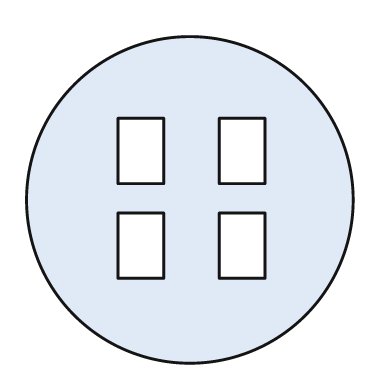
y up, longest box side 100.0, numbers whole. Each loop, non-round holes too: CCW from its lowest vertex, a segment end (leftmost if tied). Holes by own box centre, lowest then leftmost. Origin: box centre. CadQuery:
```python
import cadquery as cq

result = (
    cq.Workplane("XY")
    .moveTo(0.0, 0.0)
    .circle(50.0)
    .moveTo(-22.0, -24.0)
    .lineTo(-8.0, -24.0)
    .lineTo(-8.0, -4.0)
    .lineTo(-22.0, -4.0)
    .close()
    .moveTo(9.0, -24.0)
    .lineTo(23.0, -24.0)
    .lineTo(23.0, -4.0)
    .lineTo(9.0, -4.0)
    .close()
    .moveTo(-22.0, 5.0)
    .lineTo(-8.0, 5.0)
    .lineTo(-8.0, 25.0)
    .lineTo(-22.0, 25.0)
    .close()
    .moveTo(9.0, 5.0)
    .lineTo(23.0, 5.0)
    .lineTo(23.0, 25.0)
    .lineTo(9.0, 25.0)
    .close()
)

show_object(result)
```